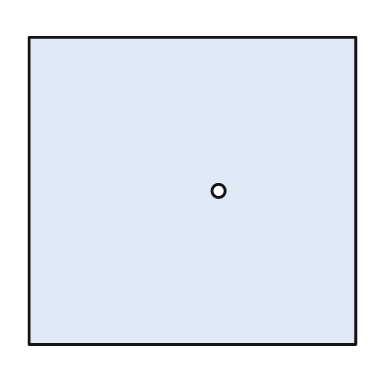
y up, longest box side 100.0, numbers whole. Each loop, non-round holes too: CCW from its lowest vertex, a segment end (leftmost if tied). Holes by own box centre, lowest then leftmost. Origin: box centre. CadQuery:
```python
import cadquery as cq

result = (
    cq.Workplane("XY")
    .moveTo(-50.0, -47.0)
    .lineTo(50.0, -47.0)
    .lineTo(50.0, 47.0)
    .lineTo(-50.0, 47.0)
    .close()
    .moveTo(8.0, 0.0)
    .circle(2.0)
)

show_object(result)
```